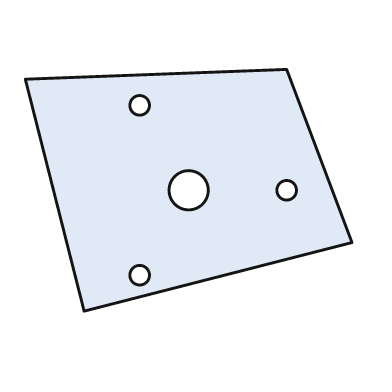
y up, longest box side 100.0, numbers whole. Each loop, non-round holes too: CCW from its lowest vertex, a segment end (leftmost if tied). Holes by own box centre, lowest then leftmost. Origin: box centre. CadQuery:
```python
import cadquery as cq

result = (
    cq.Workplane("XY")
    .moveTo(-32.0, -37.0)
    .lineTo(50.0, -16.0)
    .lineTo(30.0, 37.0)
    .lineTo(-50.0, 34.0)
    .close()
    .moveTo(-15.0, -26.0)
    .circle(3.0)
    .moveTo(0.0, 0.0)
    .circle(6.0)
    .moveTo(30.0, 0.0)
    .circle(3.0)
    .moveTo(-15.0, 26.0)
    .circle(3.0)
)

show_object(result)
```